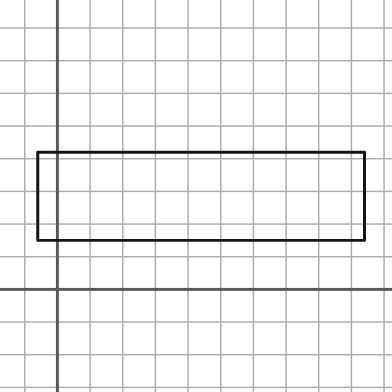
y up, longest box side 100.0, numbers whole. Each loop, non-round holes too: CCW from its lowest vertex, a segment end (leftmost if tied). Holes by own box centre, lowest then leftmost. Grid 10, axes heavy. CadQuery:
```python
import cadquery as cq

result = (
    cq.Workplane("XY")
    .moveTo(-6.0, 15.0)
    .lineTo(94.0, 15.0)
    .lineTo(94.0, 42.0)
    .lineTo(-6.0, 42.0)
    .close()
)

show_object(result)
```